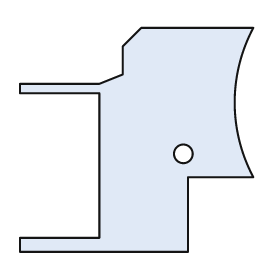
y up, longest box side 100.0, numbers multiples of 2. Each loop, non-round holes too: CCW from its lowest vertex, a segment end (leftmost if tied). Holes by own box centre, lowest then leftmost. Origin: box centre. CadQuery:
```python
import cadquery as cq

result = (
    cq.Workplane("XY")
    .moveTo(-50.0, -48.0)
    .lineTo(22.0, -48.0)
    .lineTo(22.0, -16.0)
    .lineTo(50.0, -16.0)
    .threePointArc((42.0, 16.0), (50.0, 48.0))
    .lineTo(2.0, 48.0)
    .lineTo(-6.0, 40.0)
    .lineTo(-6.0, 28.0)
    .lineTo(-16.0, 24.0)
    .lineTo(-50.0, 24.0)
    .lineTo(-50.0, 20.0)
    .lineTo(-16.0, 20.0)
    .lineTo(-16.0, -42.0)
    .lineTo(-50.0, -42.0)
    .close()
    .moveTo(20.0, -6.0)
    .circle(4.0)
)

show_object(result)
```